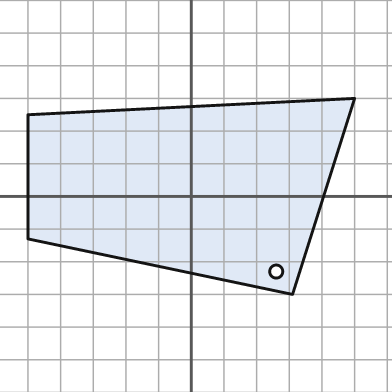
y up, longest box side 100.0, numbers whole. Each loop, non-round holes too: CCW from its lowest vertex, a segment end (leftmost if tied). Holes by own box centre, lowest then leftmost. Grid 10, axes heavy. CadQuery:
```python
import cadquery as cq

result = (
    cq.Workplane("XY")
    .moveTo(31.0, -30.0)
    .lineTo(50.0, 30.0)
    .lineTo(-50.0, 25.0)
    .lineTo(-50.0, -13.0)
    .close()
    .moveTo(26.0, -23.0)
    .circle(2.0)
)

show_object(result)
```